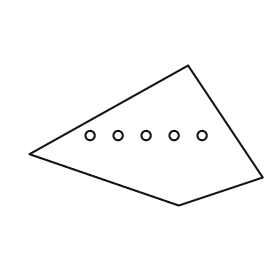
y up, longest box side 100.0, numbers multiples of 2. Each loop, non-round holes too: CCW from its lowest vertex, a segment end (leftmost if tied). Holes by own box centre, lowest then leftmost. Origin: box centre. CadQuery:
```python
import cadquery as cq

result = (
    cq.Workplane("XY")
    .moveTo(14.0, -30.0)
    .lineTo(50.0, -18.0)
    .lineTo(18.0, 30.0)
    .lineTo(-50.0, -8.0)
    .close()
    .moveTo(-24.0, 0.0)
    .circle(2.0)
    .moveTo(-12.0, 0.0)
    .circle(2.0)
    .moveTo(0.0, 0.0)
    .circle(2.0)
    .moveTo(12.0, 0.0)
    .circle(2.0)
    .moveTo(24.0, 0.0)
    .circle(2.0)
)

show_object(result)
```